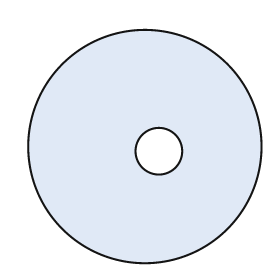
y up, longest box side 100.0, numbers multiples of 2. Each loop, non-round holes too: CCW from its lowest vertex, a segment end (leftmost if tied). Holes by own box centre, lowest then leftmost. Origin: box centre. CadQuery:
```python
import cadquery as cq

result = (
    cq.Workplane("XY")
    .moveTo(0.0, 0.0)
    .circle(50.0)
    .moveTo(6.0, -2.0)
    .circle(10.0)
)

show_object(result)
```